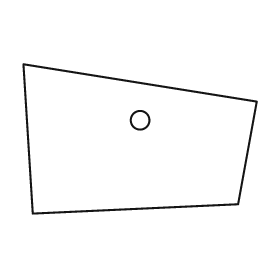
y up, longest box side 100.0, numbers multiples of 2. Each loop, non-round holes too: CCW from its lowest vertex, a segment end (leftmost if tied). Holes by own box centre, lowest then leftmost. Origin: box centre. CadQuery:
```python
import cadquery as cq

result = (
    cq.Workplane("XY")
    .moveTo(-46.0, -32.0)
    .lineTo(42.0, -28.0)
    .lineTo(50.0, 16.0)
    .lineTo(-50.0, 32.0)
    .close()
    .moveTo(0.0, 8.0)
    .circle(4.0)
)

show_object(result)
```